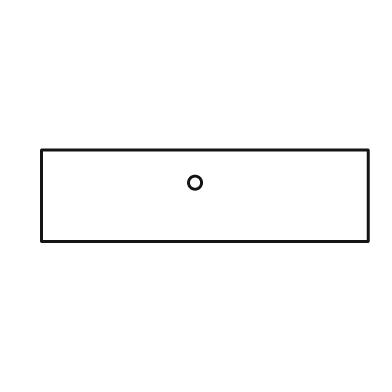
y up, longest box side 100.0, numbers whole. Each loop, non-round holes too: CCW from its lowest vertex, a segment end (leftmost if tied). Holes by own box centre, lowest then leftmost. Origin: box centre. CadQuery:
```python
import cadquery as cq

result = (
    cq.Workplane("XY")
    .moveTo(-50.0, -14.0)
    .lineTo(50.0, -14.0)
    .lineTo(50.0, 14.0)
    .lineTo(-50.0, 14.0)
    .close()
    .moveTo(-3.0, 4.0)
    .circle(2.0)
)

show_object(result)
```